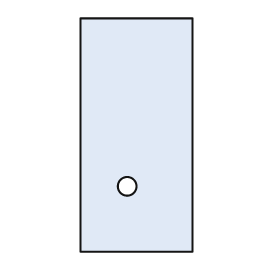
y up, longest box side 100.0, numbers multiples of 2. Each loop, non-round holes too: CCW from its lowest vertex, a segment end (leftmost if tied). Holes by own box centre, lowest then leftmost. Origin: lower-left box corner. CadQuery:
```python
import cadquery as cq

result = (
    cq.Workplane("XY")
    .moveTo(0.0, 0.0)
    .lineTo(48.0, 0.0)
    .lineTo(48.0, 100.0)
    .lineTo(0.0, 100.0)
    .close()
    .moveTo(20.0, 28.0)
    .circle(4.0)
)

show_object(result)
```